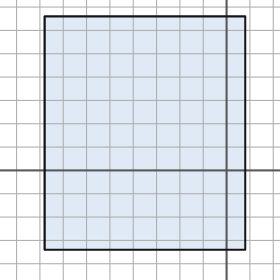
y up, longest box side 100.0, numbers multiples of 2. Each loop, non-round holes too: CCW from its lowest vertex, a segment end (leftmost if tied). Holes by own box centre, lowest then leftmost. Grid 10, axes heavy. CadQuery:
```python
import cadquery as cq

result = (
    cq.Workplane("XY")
    .moveTo(-78.0, -34.0)
    .lineTo(8.0, -34.0)
    .lineTo(8.0, 66.0)
    .lineTo(-78.0, 66.0)
    .close()
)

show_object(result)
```